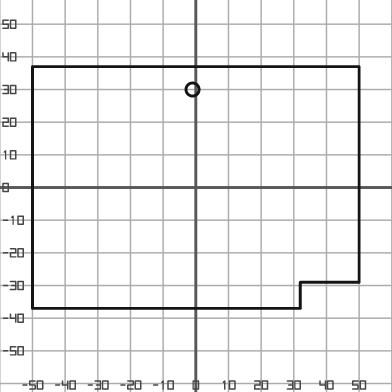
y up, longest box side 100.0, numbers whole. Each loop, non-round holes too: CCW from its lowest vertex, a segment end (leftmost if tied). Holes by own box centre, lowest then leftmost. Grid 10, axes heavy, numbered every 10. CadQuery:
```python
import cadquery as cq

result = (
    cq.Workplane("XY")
    .moveTo(-50.0, -37.0)
    .lineTo(32.0, -37.0)
    .lineTo(32.0, -29.0)
    .lineTo(50.0, -29.0)
    .lineTo(50.0, 37.0)
    .lineTo(-50.0, 37.0)
    .close()
    .moveTo(-1.0, 30.0)
    .circle(2.0)
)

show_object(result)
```